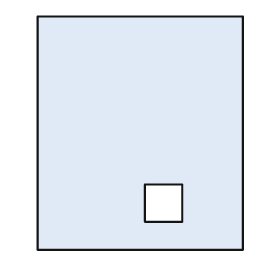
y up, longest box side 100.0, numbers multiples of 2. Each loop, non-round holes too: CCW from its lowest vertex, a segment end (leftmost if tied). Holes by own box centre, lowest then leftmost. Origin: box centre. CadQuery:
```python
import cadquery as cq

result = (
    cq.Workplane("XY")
    .moveTo(-44.0, -50.0)
    .lineTo(44.0, -50.0)
    .lineTo(44.0, 50.0)
    .lineTo(-44.0, 50.0)
    .close()
    .moveTo(2.0, -38.0)
    .lineTo(18.0, -38.0)
    .lineTo(18.0, -22.0)
    .lineTo(2.0, -22.0)
    .close()
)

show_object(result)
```